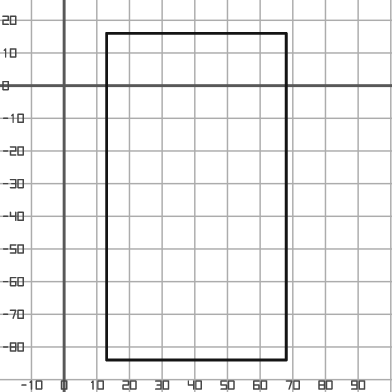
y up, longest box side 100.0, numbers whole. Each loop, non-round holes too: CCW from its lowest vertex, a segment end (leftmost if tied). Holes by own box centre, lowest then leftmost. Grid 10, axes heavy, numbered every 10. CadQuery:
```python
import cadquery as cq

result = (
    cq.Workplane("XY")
    .moveTo(13.0, -84.0)
    .lineTo(68.0, -84.0)
    .lineTo(68.0, 16.0)
    .lineTo(13.0, 16.0)
    .close()
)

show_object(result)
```